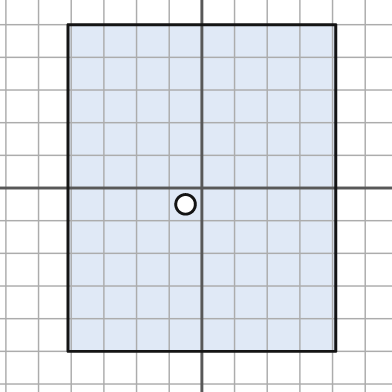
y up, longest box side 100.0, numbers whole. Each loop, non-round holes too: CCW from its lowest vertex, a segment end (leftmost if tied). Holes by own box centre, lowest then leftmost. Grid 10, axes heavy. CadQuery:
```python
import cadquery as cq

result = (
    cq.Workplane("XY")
    .moveTo(-41.0, -50.0)
    .lineTo(41.0, -50.0)
    .lineTo(41.0, 50.0)
    .lineTo(-41.0, 50.0)
    .close()
    .moveTo(-5.0, -5.0)
    .circle(3.0)
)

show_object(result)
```